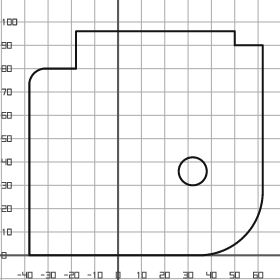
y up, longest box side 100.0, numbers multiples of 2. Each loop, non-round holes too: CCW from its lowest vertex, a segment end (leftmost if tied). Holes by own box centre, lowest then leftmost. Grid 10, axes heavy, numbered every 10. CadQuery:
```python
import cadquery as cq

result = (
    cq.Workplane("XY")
    .moveTo(-38.0, 0.0)
    .lineTo(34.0, 0.0)
    .threePointArc((54.0, 8.0), (62.0, 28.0))
    .lineTo(62.0, 90.0)
    .lineTo(50.0, 90.0)
    .lineTo(50.0, 96.0)
    .lineTo(-18.0, 96.0)
    .lineTo(-18.0, 80.0)
    .lineTo(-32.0, 80.0)
    .threePointArc((-36.0, 78.0), (-38.0, 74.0))
    .close()
    .moveTo(32.0, 36.0)
    .circle(6.0)
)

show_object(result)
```